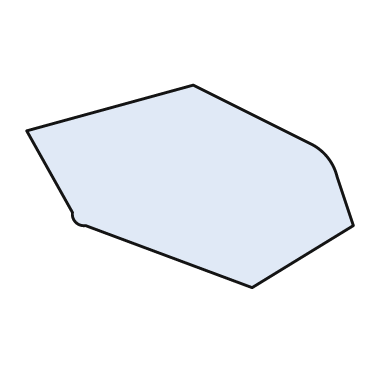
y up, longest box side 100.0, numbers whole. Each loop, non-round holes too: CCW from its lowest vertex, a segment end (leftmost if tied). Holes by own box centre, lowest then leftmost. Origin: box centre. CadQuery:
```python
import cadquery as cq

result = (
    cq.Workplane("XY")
    .moveTo(19.0, -31.0)
    .lineTo(50.0, -12.0)
    .lineTo(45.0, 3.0)
    .threePointArc((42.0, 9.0), (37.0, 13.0))
    .lineTo(1.0, 31.0)
    .lineTo(-50.0, 17.0)
    .lineTo(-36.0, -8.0)
    .threePointArc((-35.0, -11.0), (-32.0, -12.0))
    .close()
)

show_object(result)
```